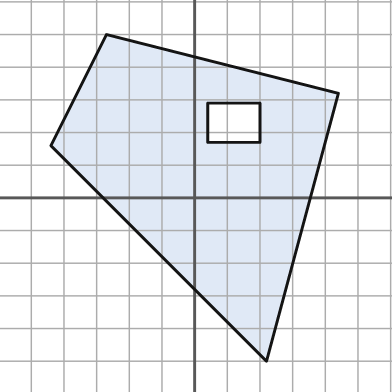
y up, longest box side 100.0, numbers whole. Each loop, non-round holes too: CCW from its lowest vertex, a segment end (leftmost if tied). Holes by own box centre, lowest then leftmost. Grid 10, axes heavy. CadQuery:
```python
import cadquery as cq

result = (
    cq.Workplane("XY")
    .moveTo(22.0, -50.0)
    .lineTo(44.0, 32.0)
    .lineTo(-27.0, 50.0)
    .lineTo(-44.0, 16.0)
    .close()
    .moveTo(4.0, 17.0)
    .lineTo(20.0, 17.0)
    .lineTo(20.0, 29.0)
    .lineTo(4.0, 29.0)
    .close()
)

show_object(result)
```